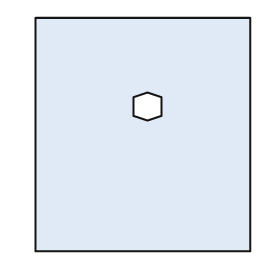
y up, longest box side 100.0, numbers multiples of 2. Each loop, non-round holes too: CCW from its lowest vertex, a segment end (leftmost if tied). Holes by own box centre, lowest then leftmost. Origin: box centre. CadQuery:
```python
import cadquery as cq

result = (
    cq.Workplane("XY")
    .moveTo(-46.0, -50.0)
    .lineTo(46.0, -50.0)
    .lineTo(46.0, 50.0)
    .lineTo(-46.0, 50.0)
    .close()
    .moveTo(2.0, 6.0)
    .lineTo(8.0, 8.0)
    .lineTo(8.0, 16.0)
    .lineTo(2.0, 18.0)
    .lineTo(-4.0, 16.0)
    .lineTo(-4.0, 8.0)
    .close()
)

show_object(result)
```